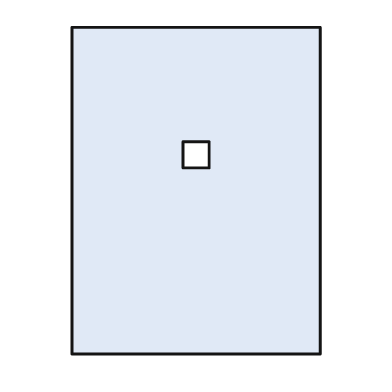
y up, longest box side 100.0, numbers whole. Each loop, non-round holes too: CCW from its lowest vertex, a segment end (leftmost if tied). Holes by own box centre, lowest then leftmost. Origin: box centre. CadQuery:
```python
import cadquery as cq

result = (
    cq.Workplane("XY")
    .moveTo(-38.0, -50.0)
    .lineTo(38.0, -50.0)
    .lineTo(38.0, 50.0)
    .lineTo(-38.0, 50.0)
    .close()
    .moveTo(-4.0, 7.0)
    .lineTo(4.0, 7.0)
    .lineTo(4.0, 15.0)
    .lineTo(-4.0, 15.0)
    .close()
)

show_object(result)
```